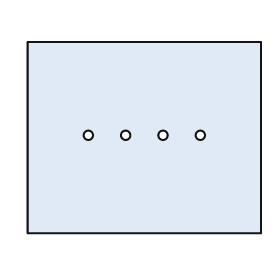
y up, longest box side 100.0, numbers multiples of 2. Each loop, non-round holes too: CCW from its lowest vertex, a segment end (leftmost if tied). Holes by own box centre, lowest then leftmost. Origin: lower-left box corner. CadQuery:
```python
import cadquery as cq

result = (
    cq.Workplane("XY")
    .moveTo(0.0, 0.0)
    .lineTo(100.0, 0.0)
    .lineTo(100.0, 82.0)
    .lineTo(0.0, 82.0)
    .close()
    .moveTo(26.0, 42.0)
    .circle(2.0)
    .moveTo(42.0, 42.0)
    .circle(2.0)
    .moveTo(58.0, 42.0)
    .circle(2.0)
    .moveTo(74.0, 42.0)
    .circle(2.0)
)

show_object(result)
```